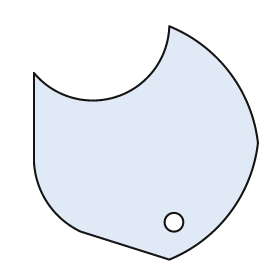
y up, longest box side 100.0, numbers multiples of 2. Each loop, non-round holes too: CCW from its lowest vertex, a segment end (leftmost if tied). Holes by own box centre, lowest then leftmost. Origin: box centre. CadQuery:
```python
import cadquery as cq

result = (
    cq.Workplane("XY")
    .moveTo(10.0, -50.0)
    .threePointArc((36.0, -30.0), (48.0, 0.0))
    .threePointArc((36.0, 30.0), (10.0, 50.0))
    .threePointArc((-12.0, 20.0), (-48.0, 30.0))
    .lineTo(-48.0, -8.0)
    .threePointArc((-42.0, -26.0), (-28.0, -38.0))
    .close()
    .moveTo(12.0, -34.0)
    .circle(4.0)
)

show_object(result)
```